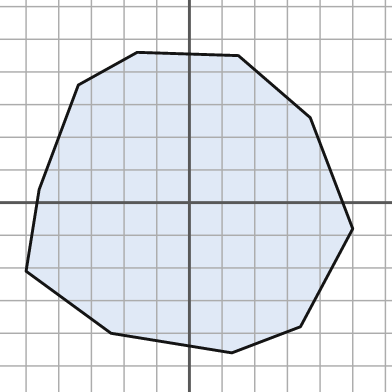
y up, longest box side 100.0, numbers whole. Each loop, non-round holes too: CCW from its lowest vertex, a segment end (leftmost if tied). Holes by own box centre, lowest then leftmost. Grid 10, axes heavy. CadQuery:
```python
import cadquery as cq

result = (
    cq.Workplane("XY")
    .moveTo(13.0, -46.0)
    .lineTo(34.0, -38.0)
    .lineTo(50.0, -8.0)
    .lineTo(37.0, 26.0)
    .lineTo(15.0, 45.0)
    .lineTo(-16.0, 46.0)
    .lineTo(-34.0, 36.0)
    .lineTo(-46.0, 4.0)
    .lineTo(-50.0, -21.0)
    .lineTo(-24.0, -40.0)
    .close()
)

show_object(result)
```